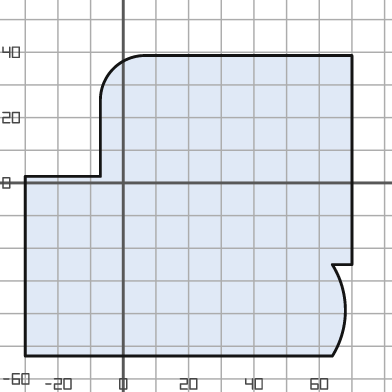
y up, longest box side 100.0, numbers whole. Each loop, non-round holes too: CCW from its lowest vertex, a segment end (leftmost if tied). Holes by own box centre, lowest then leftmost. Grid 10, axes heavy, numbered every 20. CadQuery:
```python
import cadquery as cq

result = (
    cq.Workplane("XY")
    .moveTo(-30.0, -53.0)
    .lineTo(64.0, -53.0)
    .threePointArc((68.0, -39.0), (64.0, -25.0))
    .lineTo(70.0, -25.0)
    .lineTo(70.0, 39.0)
    .lineTo(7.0, 39.0)
    .threePointArc((-3.0, 35.0), (-7.0, 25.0))
    .lineTo(-7.0, 2.0)
    .lineTo(-30.0, 2.0)
    .close()
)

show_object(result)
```